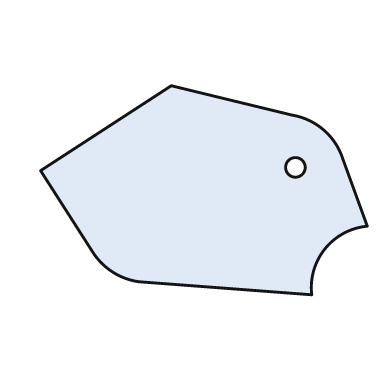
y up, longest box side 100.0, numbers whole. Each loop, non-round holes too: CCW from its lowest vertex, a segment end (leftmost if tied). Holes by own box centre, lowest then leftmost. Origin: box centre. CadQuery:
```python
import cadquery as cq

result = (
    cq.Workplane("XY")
    .moveTo(33.0, -32.0)
    .threePointArc((37.0, -18.0), (50.0, -11.0))
    .lineTo(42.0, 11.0)
    .threePointArc((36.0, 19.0), (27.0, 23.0))
    .lineTo(-10.0, 32.0)
    .lineTo(-50.0, 6.0)
    .lineTo(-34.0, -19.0)
    .threePointArc((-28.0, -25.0), (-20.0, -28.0))
    .close()
    .moveTo(28.0, 7.0)
    .circle(3.0)
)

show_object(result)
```